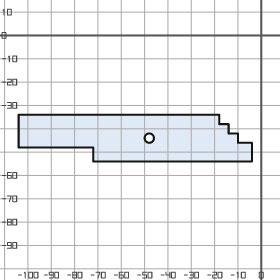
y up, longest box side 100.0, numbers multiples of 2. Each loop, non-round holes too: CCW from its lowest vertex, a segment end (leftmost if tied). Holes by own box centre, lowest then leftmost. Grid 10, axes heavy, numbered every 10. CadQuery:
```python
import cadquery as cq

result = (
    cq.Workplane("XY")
    .moveTo(-72.0, -54.0)
    .lineTo(-4.0, -54.0)
    .lineTo(-4.0, -46.0)
    .lineTo(-10.0, -46.0)
    .lineTo(-10.0, -42.0)
    .lineTo(-14.0, -42.0)
    .lineTo(-14.0, -38.0)
    .lineTo(-18.0, -38.0)
    .lineTo(-18.0, -34.0)
    .lineTo(-104.0, -34.0)
    .lineTo(-104.0, -48.0)
    .lineTo(-72.0, -48.0)
    .close()
    .moveTo(-48.0, -44.0)
    .circle(2.0)
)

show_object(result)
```